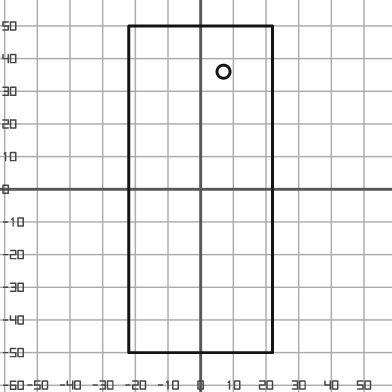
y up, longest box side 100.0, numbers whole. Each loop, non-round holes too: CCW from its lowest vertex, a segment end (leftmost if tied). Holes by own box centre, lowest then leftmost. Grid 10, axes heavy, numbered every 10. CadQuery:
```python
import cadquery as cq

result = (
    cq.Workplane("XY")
    .moveTo(-22.0, -50.0)
    .lineTo(22.0, -50.0)
    .lineTo(22.0, 50.0)
    .lineTo(-22.0, 50.0)
    .close()
    .moveTo(7.0, 36.0)
    .circle(2.0)
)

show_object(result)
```